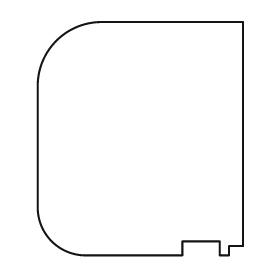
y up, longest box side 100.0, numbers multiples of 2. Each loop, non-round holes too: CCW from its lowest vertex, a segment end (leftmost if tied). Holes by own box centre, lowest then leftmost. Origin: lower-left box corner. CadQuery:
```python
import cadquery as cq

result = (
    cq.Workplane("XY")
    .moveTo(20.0, 0.0)
    .lineTo(62.0, 0.0)
    .lineTo(62.0, 6.0)
    .lineTo(78.0, 6.0)
    .lineTo(78.0, 0.0)
    .lineTo(82.0, 0.0)
    .lineTo(82.0, 4.0)
    .lineTo(88.0, 4.0)
    .lineTo(88.0, 100.0)
    .lineTo(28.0, 100.0)
    .threePointArc((8.0, 92.0), (0.0, 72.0))
    .lineTo(0.0, 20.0)
    .threePointArc((6.0, 6.0), (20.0, 0.0))
    .close()
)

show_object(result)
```